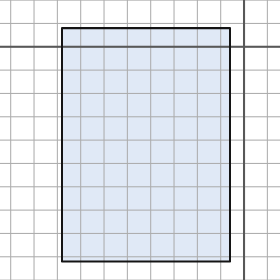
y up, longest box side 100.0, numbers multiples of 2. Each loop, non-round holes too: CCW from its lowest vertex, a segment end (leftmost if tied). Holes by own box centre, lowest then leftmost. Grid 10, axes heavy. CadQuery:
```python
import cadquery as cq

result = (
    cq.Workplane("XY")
    .moveTo(-78.0, -92.0)
    .lineTo(-6.0, -92.0)
    .lineTo(-6.0, 8.0)
    .lineTo(-78.0, 8.0)
    .close()
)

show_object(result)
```